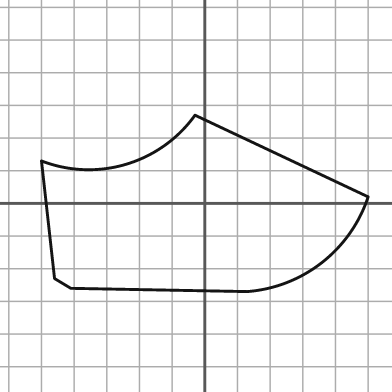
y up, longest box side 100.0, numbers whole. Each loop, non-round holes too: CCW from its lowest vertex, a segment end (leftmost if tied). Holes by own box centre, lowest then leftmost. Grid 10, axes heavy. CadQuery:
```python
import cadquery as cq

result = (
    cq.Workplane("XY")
    .moveTo(13.0, -27.0)
    .threePointArc((36.0, -18.0), (50.0, 2.0))
    .lineTo(-3.0, 27.0)
    .threePointArc((-24.0, 12.0), (-50.0, 13.0))
    .lineTo(-46.0, -23.0)
    .lineTo(-41.0, -26.0)
    .close()
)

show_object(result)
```